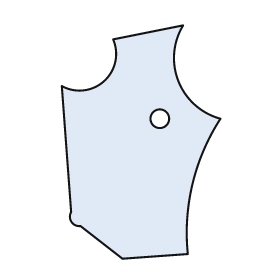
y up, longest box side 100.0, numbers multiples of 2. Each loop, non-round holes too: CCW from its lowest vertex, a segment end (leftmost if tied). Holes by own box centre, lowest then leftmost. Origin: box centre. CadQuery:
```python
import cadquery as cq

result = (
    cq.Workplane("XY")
    .moveTo(-8.0, -50.0)
    .lineTo(20.0, -48.0)
    .threePointArc((22.0, -18.0), (34.0, 10.0))
    .threePointArc((16.0, 26.0), (18.0, 50.0))
    .lineTo(-12.0, 44.0)
    .threePointArc((-16.0, 26.0), (-34.0, 24.0))
    .lineTo(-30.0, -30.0)
    .threePointArc((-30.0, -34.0), (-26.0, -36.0))
    .close()
    .moveTo(8.0, 10.0)
    .circle(4.0)
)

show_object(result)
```